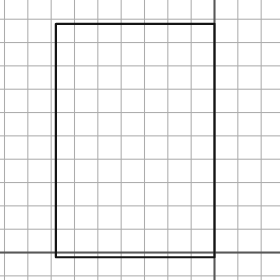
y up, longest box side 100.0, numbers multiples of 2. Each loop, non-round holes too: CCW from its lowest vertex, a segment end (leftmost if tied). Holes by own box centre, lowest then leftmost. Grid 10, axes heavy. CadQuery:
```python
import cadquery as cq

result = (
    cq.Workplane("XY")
    .moveTo(-68.0, -2.0)
    .lineTo(0.0, -2.0)
    .lineTo(0.0, 98.0)
    .lineTo(-68.0, 98.0)
    .close()
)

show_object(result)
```